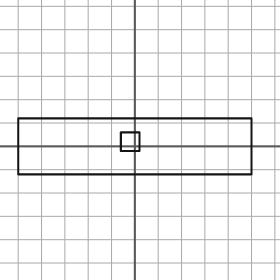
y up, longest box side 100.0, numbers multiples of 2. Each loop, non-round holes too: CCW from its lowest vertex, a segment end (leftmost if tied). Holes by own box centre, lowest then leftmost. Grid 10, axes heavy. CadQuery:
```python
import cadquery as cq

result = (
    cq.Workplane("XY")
    .moveTo(-50.0, -12.0)
    .lineTo(50.0, -12.0)
    .lineTo(50.0, 12.0)
    .lineTo(-50.0, 12.0)
    .close()
    .moveTo(-6.0, -2.0)
    .lineTo(2.0, -2.0)
    .lineTo(2.0, 6.0)
    .lineTo(-6.0, 6.0)
    .close()
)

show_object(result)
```